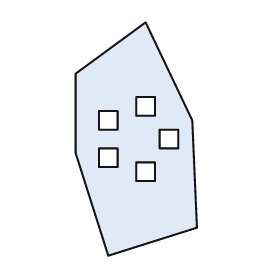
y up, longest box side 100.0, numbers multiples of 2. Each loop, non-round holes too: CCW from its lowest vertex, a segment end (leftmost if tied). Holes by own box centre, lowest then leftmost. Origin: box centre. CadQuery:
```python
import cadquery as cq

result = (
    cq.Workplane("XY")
    .moveTo(-12.0, -50.0)
    .lineTo(26.0, -38.0)
    .lineTo(24.0, 8.0)
    .lineTo(4.0, 50.0)
    .lineTo(-26.0, 28.0)
    .lineTo(-26.0, -6.0)
    .close()
    .moveTo(0.0, -18.0)
    .lineTo(8.0, -18.0)
    .lineTo(8.0, -10.0)
    .lineTo(0.0, -10.0)
    .close()
    .moveTo(-16.0, -12.0)
    .lineTo(-8.0, -12.0)
    .lineTo(-8.0, -4.0)
    .lineTo(-16.0, -4.0)
    .close()
    .moveTo(10.0, -4.0)
    .lineTo(18.0, -4.0)
    .lineTo(18.0, 4.0)
    .lineTo(10.0, 4.0)
    .close()
    .moveTo(-16.0, 4.0)
    .lineTo(-8.0, 4.0)
    .lineTo(-8.0, 12.0)
    .lineTo(-16.0, 12.0)
    .close()
    .moveTo(0.0, 10.0)
    .lineTo(8.0, 10.0)
    .lineTo(8.0, 18.0)
    .lineTo(0.0, 18.0)
    .close()
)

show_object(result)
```